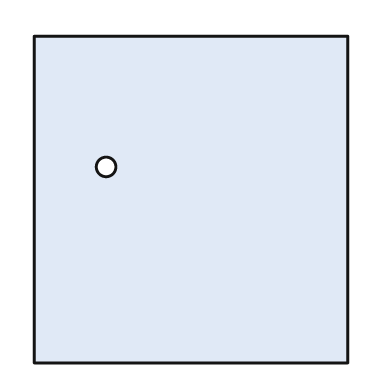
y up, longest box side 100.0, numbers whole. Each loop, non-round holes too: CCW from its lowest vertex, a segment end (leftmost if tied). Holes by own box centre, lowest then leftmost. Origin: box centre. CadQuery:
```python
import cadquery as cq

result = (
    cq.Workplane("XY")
    .moveTo(-48.0, -50.0)
    .lineTo(48.0, -50.0)
    .lineTo(48.0, 50.0)
    .lineTo(-48.0, 50.0)
    .close()
    .moveTo(-26.0, 10.0)
    .circle(3.0)
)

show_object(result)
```